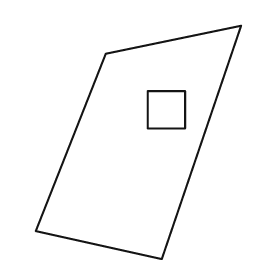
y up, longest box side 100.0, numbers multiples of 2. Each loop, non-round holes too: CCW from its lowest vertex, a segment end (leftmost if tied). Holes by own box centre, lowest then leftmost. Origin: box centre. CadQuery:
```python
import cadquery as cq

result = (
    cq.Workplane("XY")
    .moveTo(10.0, -50.0)
    .lineTo(44.0, 50.0)
    .lineTo(-14.0, 38.0)
    .lineTo(-44.0, -38.0)
    .close()
    .moveTo(4.0, 6.0)
    .lineTo(20.0, 6.0)
    .lineTo(20.0, 22.0)
    .lineTo(4.0, 22.0)
    .close()
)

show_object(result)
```